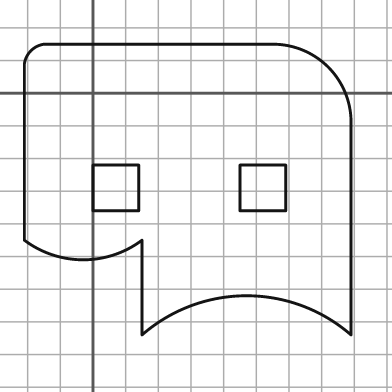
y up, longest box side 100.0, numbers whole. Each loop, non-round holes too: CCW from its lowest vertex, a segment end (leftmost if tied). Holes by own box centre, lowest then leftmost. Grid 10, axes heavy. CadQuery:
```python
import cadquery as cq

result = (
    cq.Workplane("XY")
    .moveTo(15.0, -74.0)
    .threePointArc((47.0, -62.0), (79.0, -74.0))
    .lineTo(79.0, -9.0)
    .threePointArc((72.0, 8.0), (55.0, 15.0))
    .lineTo(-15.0, 15.0)
    .threePointArc((-19.0, 13.0), (-21.0, 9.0))
    .lineTo(-21.0, -45.0)
    .threePointArc((-3.0, -51.0), (15.0, -45.0))
    .close()
    .moveTo(0.0, -36.0)
    .lineTo(14.0, -36.0)
    .lineTo(14.0, -22.0)
    .lineTo(0.0, -22.0)
    .close()
    .moveTo(45.0, -36.0)
    .lineTo(59.0, -36.0)
    .lineTo(59.0, -22.0)
    .lineTo(45.0, -22.0)
    .close()
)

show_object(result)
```